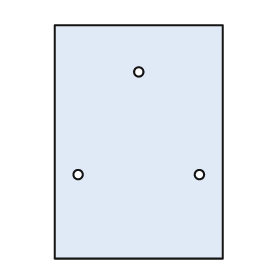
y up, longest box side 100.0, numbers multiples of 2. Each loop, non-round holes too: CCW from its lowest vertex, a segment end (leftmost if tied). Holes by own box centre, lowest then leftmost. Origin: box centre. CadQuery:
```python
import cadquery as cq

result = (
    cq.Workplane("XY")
    .moveTo(-36.0, -50.0)
    .lineTo(36.0, -50.0)
    .lineTo(36.0, 50.0)
    .lineTo(-36.0, 50.0)
    .close()
    .moveTo(-26.0, -14.0)
    .circle(2.0)
    .moveTo(26.0, -14.0)
    .circle(2.0)
    .moveTo(0.0, 30.0)
    .circle(2.0)
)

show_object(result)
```